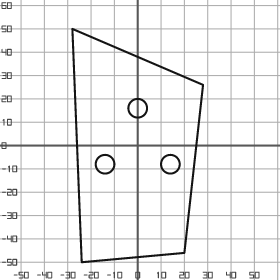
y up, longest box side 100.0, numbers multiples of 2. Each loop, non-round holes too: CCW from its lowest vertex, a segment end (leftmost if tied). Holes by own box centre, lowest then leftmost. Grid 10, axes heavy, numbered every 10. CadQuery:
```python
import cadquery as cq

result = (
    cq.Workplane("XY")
    .moveTo(-24.0, -50.0)
    .lineTo(20.0, -46.0)
    .lineTo(28.0, 26.0)
    .lineTo(-28.0, 50.0)
    .close()
    .moveTo(-14.0, -8.0)
    .circle(4.0)
    .moveTo(14.0, -8.0)
    .circle(4.0)
    .moveTo(0.0, 16.0)
    .circle(4.0)
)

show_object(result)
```